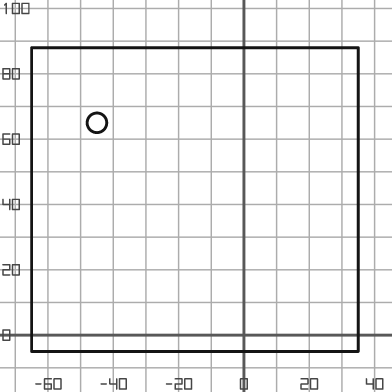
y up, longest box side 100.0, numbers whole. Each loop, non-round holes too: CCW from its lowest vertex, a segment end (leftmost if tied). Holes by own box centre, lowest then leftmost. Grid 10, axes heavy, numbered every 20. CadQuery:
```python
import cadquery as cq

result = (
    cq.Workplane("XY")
    .moveTo(-65.0, -5.0)
    .lineTo(35.0, -5.0)
    .lineTo(35.0, 88.0)
    .lineTo(-65.0, 88.0)
    .close()
    .moveTo(-45.0, 65.0)
    .circle(3.0)
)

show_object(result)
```